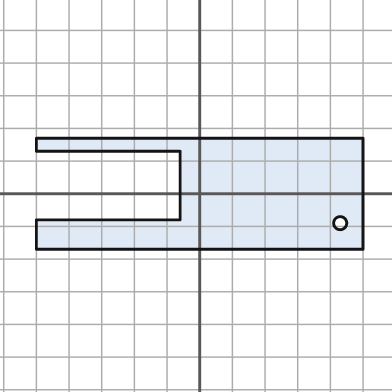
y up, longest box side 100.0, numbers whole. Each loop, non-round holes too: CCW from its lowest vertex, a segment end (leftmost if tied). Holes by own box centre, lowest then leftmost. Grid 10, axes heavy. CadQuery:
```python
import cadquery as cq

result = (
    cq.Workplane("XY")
    .moveTo(-50.0, -17.0)
    .lineTo(50.0, -17.0)
    .lineTo(50.0, 17.0)
    .lineTo(-50.0, 17.0)
    .lineTo(-50.0, 13.0)
    .lineTo(-6.0, 13.0)
    .lineTo(-6.0, -8.0)
    .lineTo(-50.0, -8.0)
    .close()
    .moveTo(43.0, -9.0)
    .circle(2.0)
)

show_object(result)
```